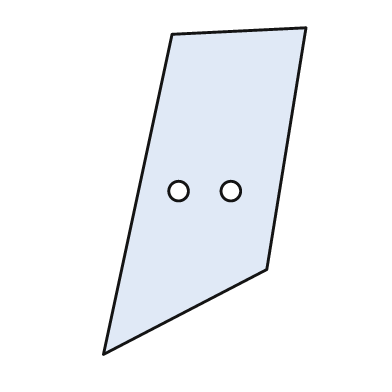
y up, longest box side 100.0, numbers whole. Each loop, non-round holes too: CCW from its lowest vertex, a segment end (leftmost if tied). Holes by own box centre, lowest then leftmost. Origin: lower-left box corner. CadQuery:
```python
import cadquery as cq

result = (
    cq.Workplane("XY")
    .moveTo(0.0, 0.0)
    .lineTo(50.0, 26.0)
    .lineTo(62.0, 100.0)
    .lineTo(21.0, 98.0)
    .close()
    .moveTo(23.0, 50.0)
    .circle(3.0)
    .moveTo(39.0, 50.0)
    .circle(3.0)
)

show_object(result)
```